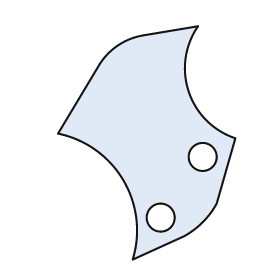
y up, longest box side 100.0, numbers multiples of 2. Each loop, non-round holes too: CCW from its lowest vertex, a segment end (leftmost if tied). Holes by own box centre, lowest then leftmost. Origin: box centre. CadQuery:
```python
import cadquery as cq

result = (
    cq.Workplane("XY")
    .moveTo(-6.0, -50.0)
    .lineTo(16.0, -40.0)
    .threePointArc((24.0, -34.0), (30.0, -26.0))
    .lineTo(38.0, 2.0)
    .threePointArc((18.0, 22.0), (22.0, 50.0))
    .lineTo(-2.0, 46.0)
    .threePointArc((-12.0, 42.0), (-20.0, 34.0))
    .lineTo(-38.0, 4.0)
    .threePointArc((-10.0, -16.0), (-6.0, -50.0))
    .close()
    .moveTo(6.0, -32.0)
    .circle(6.0)
    .moveTo(24.0, -6.0)
    .circle(6.0)
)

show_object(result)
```